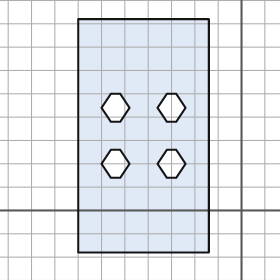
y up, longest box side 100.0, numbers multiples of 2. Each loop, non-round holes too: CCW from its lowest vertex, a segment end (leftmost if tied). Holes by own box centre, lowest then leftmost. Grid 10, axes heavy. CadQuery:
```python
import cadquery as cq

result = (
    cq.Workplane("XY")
    .moveTo(-70.0, -18.0)
    .lineTo(-14.0, -18.0)
    .lineTo(-14.0, 82.0)
    .lineTo(-70.0, 82.0)
    .close()
    .moveTo(-56.0, 14.0)
    .lineTo(-52.0, 14.0)
    .lineTo(-48.0, 20.0)
    .lineTo(-52.0, 26.0)
    .lineTo(-56.0, 26.0)
    .lineTo(-60.0, 20.0)
    .close()
    .moveTo(-32.0, 14.0)
    .lineTo(-28.0, 14.0)
    .lineTo(-24.0, 20.0)
    .lineTo(-28.0, 26.0)
    .lineTo(-32.0, 26.0)
    .lineTo(-36.0, 20.0)
    .close()
    .moveTo(-56.0, 38.0)
    .lineTo(-52.0, 38.0)
    .lineTo(-48.0, 44.0)
    .lineTo(-52.0, 50.0)
    .lineTo(-56.0, 50.0)
    .lineTo(-60.0, 44.0)
    .close()
    .moveTo(-32.0, 38.0)
    .lineTo(-28.0, 38.0)
    .lineTo(-24.0, 44.0)
    .lineTo(-28.0, 50.0)
    .lineTo(-32.0, 50.0)
    .lineTo(-36.0, 44.0)
    .close()
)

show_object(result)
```